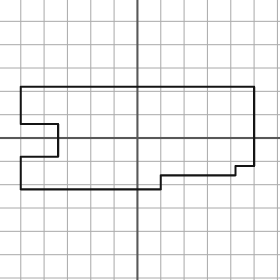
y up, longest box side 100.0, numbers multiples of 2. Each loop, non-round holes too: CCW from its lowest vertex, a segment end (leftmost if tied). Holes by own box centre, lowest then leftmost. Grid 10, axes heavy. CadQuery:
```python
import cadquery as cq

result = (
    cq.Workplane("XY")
    .moveTo(-50.0, -22.0)
    .lineTo(10.0, -22.0)
    .lineTo(10.0, -16.0)
    .lineTo(42.0, -16.0)
    .lineTo(42.0, -12.0)
    .lineTo(50.0, -12.0)
    .lineTo(50.0, 22.0)
    .lineTo(-50.0, 22.0)
    .lineTo(-50.0, 6.0)
    .lineTo(-34.0, 6.0)
    .lineTo(-34.0, -8.0)
    .lineTo(-50.0, -8.0)
    .close()
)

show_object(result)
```